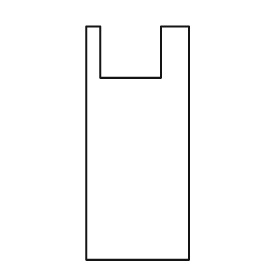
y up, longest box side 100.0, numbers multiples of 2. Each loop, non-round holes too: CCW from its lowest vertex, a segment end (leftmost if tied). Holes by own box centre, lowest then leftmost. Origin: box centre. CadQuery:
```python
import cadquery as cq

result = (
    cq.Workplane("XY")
    .moveTo(-22.0, -50.0)
    .lineTo(22.0, -50.0)
    .lineTo(22.0, 50.0)
    .lineTo(10.0, 50.0)
    .lineTo(10.0, 28.0)
    .lineTo(-16.0, 28.0)
    .lineTo(-16.0, 50.0)
    .lineTo(-22.0, 50.0)
    .close()
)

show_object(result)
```